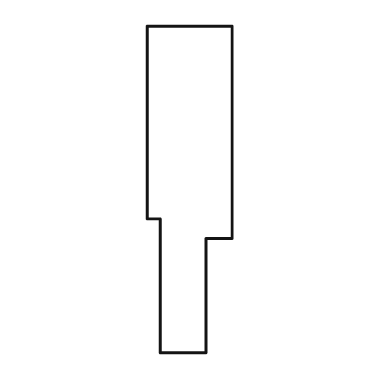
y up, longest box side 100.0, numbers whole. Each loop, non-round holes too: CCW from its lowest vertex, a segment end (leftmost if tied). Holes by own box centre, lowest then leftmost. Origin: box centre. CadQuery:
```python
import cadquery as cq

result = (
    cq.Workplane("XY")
    .moveTo(-9.0, -50.0)
    .lineTo(5.0, -50.0)
    .lineTo(5.0, -15.0)
    .lineTo(13.0, -15.0)
    .lineTo(13.0, 50.0)
    .lineTo(-13.0, 50.0)
    .lineTo(-13.0, -9.0)
    .lineTo(-9.0, -9.0)
    .close()
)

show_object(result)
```